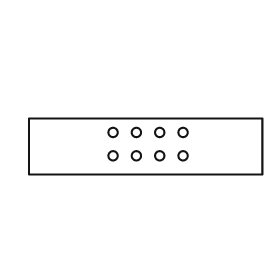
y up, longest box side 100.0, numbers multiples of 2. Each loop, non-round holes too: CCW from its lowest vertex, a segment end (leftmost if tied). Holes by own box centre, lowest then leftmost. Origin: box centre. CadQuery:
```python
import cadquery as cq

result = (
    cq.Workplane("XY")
    .moveTo(-50.0, -12.0)
    .lineTo(50.0, -12.0)
    .lineTo(50.0, 12.0)
    .lineTo(-50.0, 12.0)
    .close()
    .moveTo(-14.0, -4.0)
    .circle(2.0)
    .moveTo(-4.0, -4.0)
    .circle(2.0)
    .moveTo(6.0, -4.0)
    .circle(2.0)
    .moveTo(16.0, -4.0)
    .circle(2.0)
    .moveTo(-14.0, 6.0)
    .circle(2.0)
    .moveTo(-4.0, 6.0)
    .circle(2.0)
    .moveTo(6.0, 6.0)
    .circle(2.0)
    .moveTo(16.0, 6.0)
    .circle(2.0)
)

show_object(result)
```